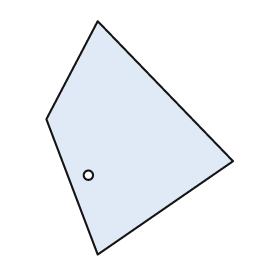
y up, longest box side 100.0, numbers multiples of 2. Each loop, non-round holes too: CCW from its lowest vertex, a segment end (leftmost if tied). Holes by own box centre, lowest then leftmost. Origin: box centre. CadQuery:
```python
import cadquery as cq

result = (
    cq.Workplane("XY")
    .moveTo(-18.0, -50.0)
    .lineTo(40.0, -10.0)
    .lineTo(-18.0, 50.0)
    .lineTo(-40.0, 8.0)
    .close()
    .moveTo(-22.0, -16.0)
    .circle(2.0)
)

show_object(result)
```